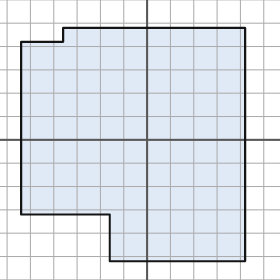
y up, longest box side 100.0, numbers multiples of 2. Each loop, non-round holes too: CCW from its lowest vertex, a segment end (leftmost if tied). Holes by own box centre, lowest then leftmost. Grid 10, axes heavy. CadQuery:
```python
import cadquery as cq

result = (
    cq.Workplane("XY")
    .moveTo(-16.0, -52.0)
    .lineTo(42.0, -52.0)
    .lineTo(42.0, 48.0)
    .lineTo(-36.0, 48.0)
    .lineTo(-36.0, 42.0)
    .lineTo(-54.0, 42.0)
    .lineTo(-54.0, -32.0)
    .lineTo(-16.0, -32.0)
    .close()
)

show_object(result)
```